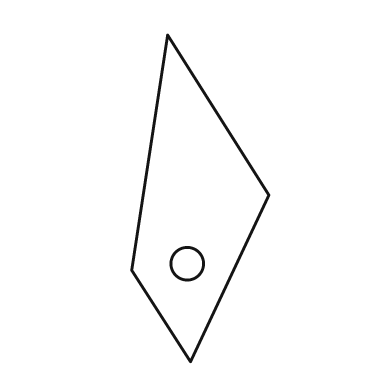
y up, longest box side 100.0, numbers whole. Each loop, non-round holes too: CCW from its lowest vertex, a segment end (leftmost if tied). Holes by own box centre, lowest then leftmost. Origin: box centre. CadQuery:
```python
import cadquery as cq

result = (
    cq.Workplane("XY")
    .moveTo(-3.0, -50.0)
    .lineTo(21.0, 1.0)
    .lineTo(-10.0, 50.0)
    .lineTo(-21.0, -22.0)
    .close()
    .moveTo(-4.0, -20.0)
    .circle(5.0)
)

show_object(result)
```